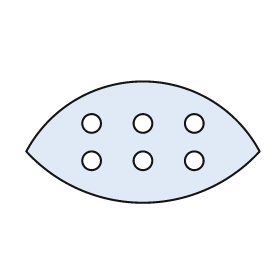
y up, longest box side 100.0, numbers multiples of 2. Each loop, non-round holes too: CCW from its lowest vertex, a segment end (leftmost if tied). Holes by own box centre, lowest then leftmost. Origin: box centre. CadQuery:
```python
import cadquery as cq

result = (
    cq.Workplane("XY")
    .moveTo(-50.0, -4.0)
    .threePointArc((0.0, -26.0), (50.0, -4.0))
    .threePointArc((0.0, 26.0), (-50.0, -4.0))
    .close()
    .moveTo(-22.0, -8.0)
    .circle(4.0)
    .moveTo(0.0, -8.0)
    .circle(4.0)
    .moveTo(22.0, -8.0)
    .circle(4.0)
    .moveTo(-22.0, 8.0)
    .circle(4.0)
    .moveTo(0.0, 8.0)
    .circle(4.0)
    .moveTo(22.0, 8.0)
    .circle(4.0)
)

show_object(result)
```